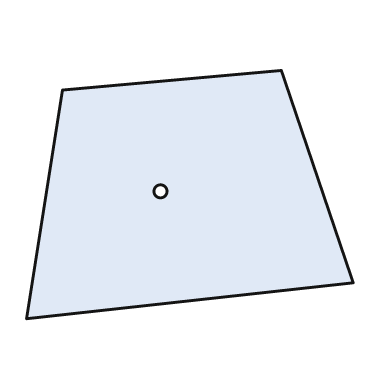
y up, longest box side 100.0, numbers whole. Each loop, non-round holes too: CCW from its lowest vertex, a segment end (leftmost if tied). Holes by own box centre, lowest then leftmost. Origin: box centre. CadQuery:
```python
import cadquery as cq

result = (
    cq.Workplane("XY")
    .moveTo(-50.0, -38.0)
    .lineTo(50.0, -27.0)
    .lineTo(28.0, 38.0)
    .lineTo(-39.0, 32.0)
    .close()
    .moveTo(-9.0, 1.0)
    .circle(2.0)
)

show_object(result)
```